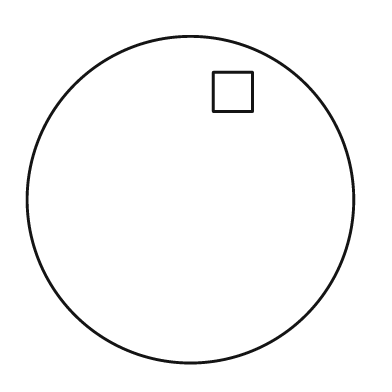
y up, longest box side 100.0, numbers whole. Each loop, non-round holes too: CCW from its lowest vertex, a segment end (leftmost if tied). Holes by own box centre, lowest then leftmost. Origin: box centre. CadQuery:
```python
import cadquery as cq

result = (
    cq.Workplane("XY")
    .moveTo(0.0, 0.0)
    .circle(50.0)
    .moveTo(7.0, 27.0)
    .lineTo(19.0, 27.0)
    .lineTo(19.0, 39.0)
    .lineTo(7.0, 39.0)
    .close()
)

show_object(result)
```